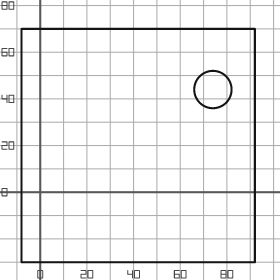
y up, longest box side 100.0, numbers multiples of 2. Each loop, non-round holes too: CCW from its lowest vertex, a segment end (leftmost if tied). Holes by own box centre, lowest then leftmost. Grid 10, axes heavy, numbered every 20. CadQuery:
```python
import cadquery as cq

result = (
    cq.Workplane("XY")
    .moveTo(-8.0, -30.0)
    .lineTo(92.0, -30.0)
    .lineTo(92.0, 70.0)
    .lineTo(-8.0, 70.0)
    .close()
    .moveTo(74.0, 44.0)
    .circle(8.0)
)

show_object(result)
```